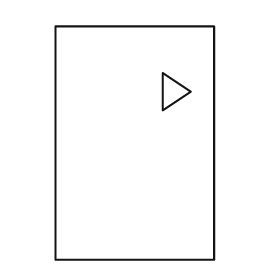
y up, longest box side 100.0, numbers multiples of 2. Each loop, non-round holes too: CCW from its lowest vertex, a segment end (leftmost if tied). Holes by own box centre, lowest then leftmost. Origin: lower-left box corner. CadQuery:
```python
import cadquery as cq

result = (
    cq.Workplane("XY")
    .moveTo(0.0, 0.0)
    .lineTo(68.0, 0.0)
    .lineTo(68.0, 100.0)
    .lineTo(0.0, 100.0)
    .close()
    .moveTo(46.0, 64.0)
    .lineTo(58.0, 72.0)
    .lineTo(46.0, 80.0)
    .close()
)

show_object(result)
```